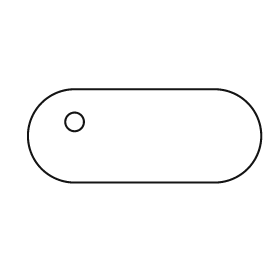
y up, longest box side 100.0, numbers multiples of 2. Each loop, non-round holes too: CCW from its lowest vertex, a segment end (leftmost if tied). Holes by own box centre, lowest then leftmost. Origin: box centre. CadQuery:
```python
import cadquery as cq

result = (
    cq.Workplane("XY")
    .moveTo(-30.0, -20.0)
    .lineTo(30.0, -20.0)
    .threePointArc((50.0, 0.0), (30.0, 20.0))
    .lineTo(-30.0, 20.0)
    .threePointArc((-50.0, 0.0), (-30.0, -20.0))
    .close()
    .moveTo(-30.0, 6.0)
    .circle(4.0)
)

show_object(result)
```